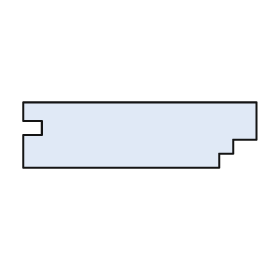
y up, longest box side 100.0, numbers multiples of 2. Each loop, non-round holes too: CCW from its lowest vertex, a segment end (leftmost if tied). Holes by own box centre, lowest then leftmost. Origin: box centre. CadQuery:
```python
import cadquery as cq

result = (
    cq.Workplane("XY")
    .moveTo(-50.0, -14.0)
    .lineTo(34.0, -14.0)
    .lineTo(34.0, -8.0)
    .lineTo(40.0, -8.0)
    .lineTo(40.0, -2.0)
    .lineTo(50.0, -2.0)
    .lineTo(50.0, 14.0)
    .lineTo(-50.0, 14.0)
    .lineTo(-50.0, 6.0)
    .lineTo(-42.0, 6.0)
    .lineTo(-42.0, 0.0)
    .lineTo(-50.0, 0.0)
    .close()
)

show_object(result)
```